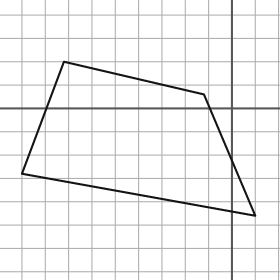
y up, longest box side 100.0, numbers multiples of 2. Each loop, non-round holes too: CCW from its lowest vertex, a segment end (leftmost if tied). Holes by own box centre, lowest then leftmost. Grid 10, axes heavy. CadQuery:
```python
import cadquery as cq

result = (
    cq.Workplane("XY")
    .moveTo(10.0, -46.0)
    .lineTo(-12.0, 6.0)
    .lineTo(-72.0, 20.0)
    .lineTo(-90.0, -28.0)
    .close()
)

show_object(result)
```